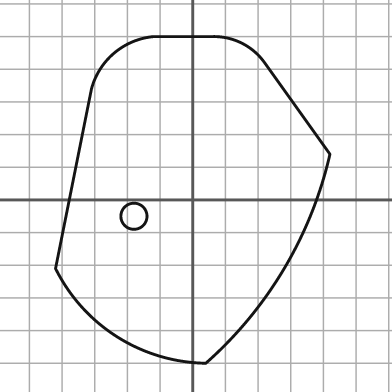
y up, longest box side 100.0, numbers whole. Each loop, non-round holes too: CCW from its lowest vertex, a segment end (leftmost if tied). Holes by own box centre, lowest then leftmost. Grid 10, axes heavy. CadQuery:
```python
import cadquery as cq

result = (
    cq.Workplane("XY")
    .moveTo(4.0, -50.0)
    .threePointArc((28.0, -21.0), (42.0, 14.0))
    .lineTo(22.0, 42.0)
    .threePointArc((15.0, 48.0), (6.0, 50.0))
    .lineTo(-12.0, 50.0)
    .threePointArc((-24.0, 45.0), (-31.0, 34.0))
    .lineTo(-42.0, -21.0)
    .threePointArc((-23.0, -42.0), (4.0, -50.0))
    .close()
    .moveTo(-18.0, -5.0)
    .circle(4.0)
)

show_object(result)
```